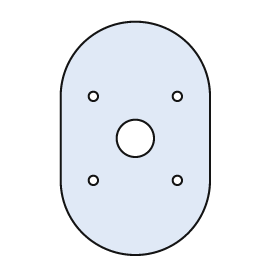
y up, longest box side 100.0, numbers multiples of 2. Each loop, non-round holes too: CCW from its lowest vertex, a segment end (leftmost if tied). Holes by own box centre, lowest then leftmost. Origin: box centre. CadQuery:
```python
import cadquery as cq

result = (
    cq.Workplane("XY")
    .moveTo(-32.0, -18.0)
    .threePointArc((0.0, -50.0), (32.0, -18.0))
    .lineTo(32.0, 18.0)
    .threePointArc((0.0, 50.0), (-32.0, 18.0))
    .close()
    .moveTo(-18.0, -18.0)
    .circle(2.0)
    .moveTo(18.0, -18.0)
    .circle(2.0)
    .moveTo(0.0, 0.0)
    .circle(8.0)
    .moveTo(-18.0, 18.0)
    .circle(2.0)
    .moveTo(18.0, 18.0)
    .circle(2.0)
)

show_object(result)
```